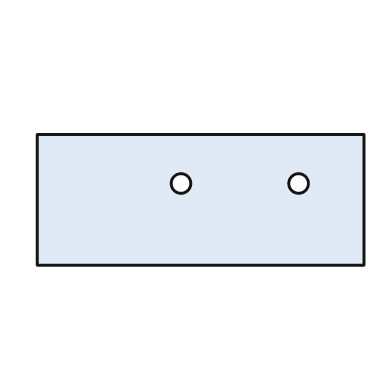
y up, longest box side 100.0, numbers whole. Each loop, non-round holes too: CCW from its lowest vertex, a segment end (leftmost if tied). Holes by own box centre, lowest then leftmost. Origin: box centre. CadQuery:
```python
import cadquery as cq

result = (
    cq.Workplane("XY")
    .moveTo(-50.0, -20.0)
    .lineTo(50.0, -20.0)
    .lineTo(50.0, 20.0)
    .lineTo(-50.0, 20.0)
    .close()
    .moveTo(-6.0, 5.0)
    .circle(3.0)
    .moveTo(30.0, 5.0)
    .circle(3.0)
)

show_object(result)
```